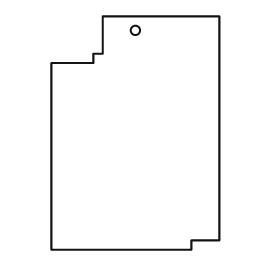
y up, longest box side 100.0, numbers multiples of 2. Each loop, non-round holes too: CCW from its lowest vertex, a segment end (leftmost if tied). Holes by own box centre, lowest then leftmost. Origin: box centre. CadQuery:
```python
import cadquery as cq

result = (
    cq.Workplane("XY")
    .moveTo(-36.0, -50.0)
    .lineTo(24.0, -50.0)
    .lineTo(24.0, -46.0)
    .lineTo(36.0, -46.0)
    .lineTo(36.0, 50.0)
    .lineTo(-14.0, 50.0)
    .lineTo(-14.0, 34.0)
    .lineTo(-18.0, 34.0)
    .lineTo(-18.0, 30.0)
    .lineTo(-36.0, 30.0)
    .close()
    .moveTo(0.0, 44.0)
    .circle(2.0)
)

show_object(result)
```